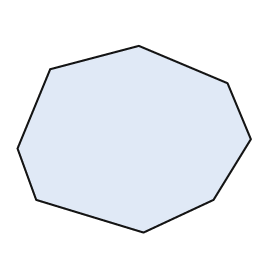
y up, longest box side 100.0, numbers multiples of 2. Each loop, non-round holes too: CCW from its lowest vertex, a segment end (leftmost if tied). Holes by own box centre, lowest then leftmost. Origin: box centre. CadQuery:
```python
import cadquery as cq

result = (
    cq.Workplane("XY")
    .moveTo(4.0, -40.0)
    .lineTo(34.0, -26.0)
    .lineTo(50.0, 0.0)
    .lineTo(40.0, 24.0)
    .lineTo(2.0, 40.0)
    .lineTo(-36.0, 30.0)
    .lineTo(-50.0, -4.0)
    .lineTo(-42.0, -26.0)
    .close()
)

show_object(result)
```